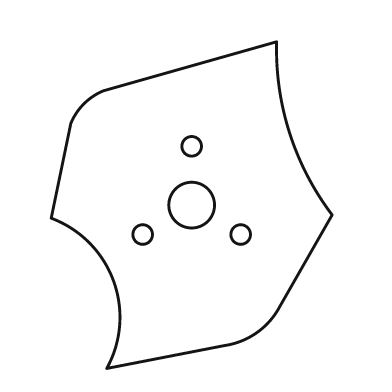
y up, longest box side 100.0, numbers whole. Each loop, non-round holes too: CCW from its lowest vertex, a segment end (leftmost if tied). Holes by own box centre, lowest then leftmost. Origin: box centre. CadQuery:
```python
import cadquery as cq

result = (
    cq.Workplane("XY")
    .moveTo(-26.0, -50.0)
    .lineTo(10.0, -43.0)
    .threePointArc((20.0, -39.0), (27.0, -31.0))
    .lineTo(43.0, -3.0)
    .threePointArc((30.0, 22.0), (26.0, 50.0))
    .lineTo(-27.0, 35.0)
    .threePointArc((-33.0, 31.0), (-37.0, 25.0))
    .lineTo(-43.0, -4.0)
    .threePointArc((-24.0, -23.0), (-26.0, -50.0))
    .close()
    .moveTo(-15.0, -9.0)
    .circle(3.0)
    .moveTo(15.0, -9.0)
    .circle(3.0)
    .moveTo(0.0, 0.0)
    .circle(7.0)
    .moveTo(0.0, 18.0)
    .circle(3.0)
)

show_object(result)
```